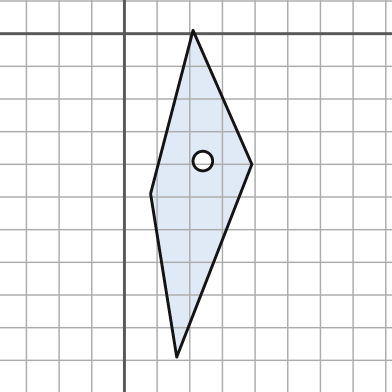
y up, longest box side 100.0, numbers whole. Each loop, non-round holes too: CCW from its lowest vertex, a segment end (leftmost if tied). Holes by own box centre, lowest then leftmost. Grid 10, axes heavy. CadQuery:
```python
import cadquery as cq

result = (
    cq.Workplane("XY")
    .moveTo(16.0, -99.0)
    .lineTo(39.0, -40.0)
    .lineTo(21.0, 1.0)
    .lineTo(8.0, -49.0)
    .close()
    .moveTo(24.0, -39.0)
    .circle(3.0)
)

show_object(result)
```